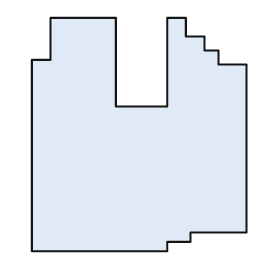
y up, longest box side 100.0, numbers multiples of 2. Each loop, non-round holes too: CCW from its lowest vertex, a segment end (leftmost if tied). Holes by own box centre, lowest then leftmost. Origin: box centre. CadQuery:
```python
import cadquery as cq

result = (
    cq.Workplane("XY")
    .moveTo(-46.0, -50.0)
    .lineTo(12.0, -50.0)
    .lineTo(12.0, -46.0)
    .lineTo(22.0, -46.0)
    .lineTo(22.0, -42.0)
    .lineTo(46.0, -42.0)
    .lineTo(46.0, 30.0)
    .lineTo(34.0, 30.0)
    .lineTo(34.0, 36.0)
    .lineTo(28.0, 36.0)
    .lineTo(28.0, 42.0)
    .lineTo(20.0, 42.0)
    .lineTo(20.0, 50.0)
    .lineTo(12.0, 50.0)
    .lineTo(12.0, 12.0)
    .lineTo(-10.0, 12.0)
    .lineTo(-10.0, 50.0)
    .lineTo(-38.0, 50.0)
    .lineTo(-38.0, 32.0)
    .lineTo(-46.0, 32.0)
    .close()
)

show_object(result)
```